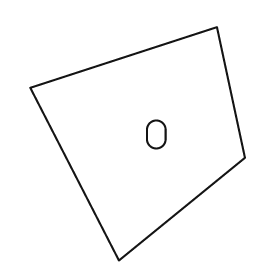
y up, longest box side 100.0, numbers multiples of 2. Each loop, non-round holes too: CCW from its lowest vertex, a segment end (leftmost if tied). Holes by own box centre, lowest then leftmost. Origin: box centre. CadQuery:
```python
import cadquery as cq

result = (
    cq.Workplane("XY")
    .moveTo(-8.0, -50.0)
    .lineTo(46.0, -6.0)
    .lineTo(34.0, 50.0)
    .lineTo(-46.0, 24.0)
    .close()
    .moveTo(4.0, 2.0)
    .threePointArc((8.0, -2.0), (12.0, 2.0))
    .lineTo(12.0, 6.0)
    .threePointArc((8.0, 10.0), (4.0, 6.0))
    .close()
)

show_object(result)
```